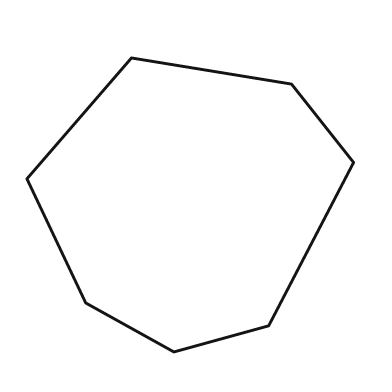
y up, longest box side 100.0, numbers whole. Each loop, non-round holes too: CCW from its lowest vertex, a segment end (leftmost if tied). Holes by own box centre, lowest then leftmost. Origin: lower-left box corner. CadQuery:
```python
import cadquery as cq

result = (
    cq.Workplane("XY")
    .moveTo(45.0, 0.0)
    .lineTo(74.0, 8.0)
    .lineTo(100.0, 58.0)
    .lineTo(81.0, 82.0)
    .lineTo(32.0, 90.0)
    .lineTo(0.0, 53.0)
    .lineTo(18.0, 15.0)
    .close()
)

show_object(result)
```